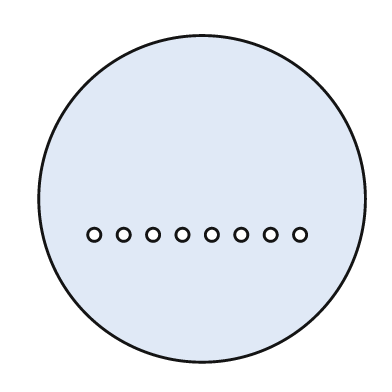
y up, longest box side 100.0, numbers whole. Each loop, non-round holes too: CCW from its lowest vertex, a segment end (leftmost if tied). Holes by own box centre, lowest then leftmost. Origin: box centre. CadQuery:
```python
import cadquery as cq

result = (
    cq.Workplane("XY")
    .moveTo(0.0, 0.0)
    .circle(50.0)
    .moveTo(-33.0, -11.0)
    .circle(2.0)
    .moveTo(-24.0, -11.0)
    .circle(2.0)
    .moveTo(-15.0, -11.0)
    .circle(2.0)
    .moveTo(-6.0, -11.0)
    .circle(2.0)
    .moveTo(3.0, -11.0)
    .circle(2.0)
    .moveTo(12.0, -11.0)
    .circle(2.0)
    .moveTo(21.0, -11.0)
    .circle(2.0)
    .moveTo(30.0, -11.0)
    .circle(2.0)
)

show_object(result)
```